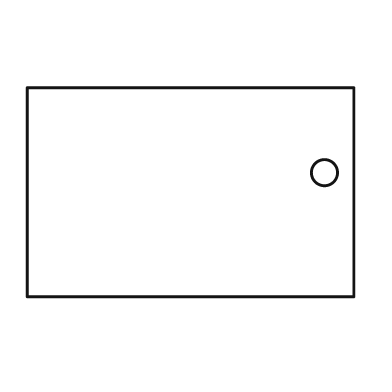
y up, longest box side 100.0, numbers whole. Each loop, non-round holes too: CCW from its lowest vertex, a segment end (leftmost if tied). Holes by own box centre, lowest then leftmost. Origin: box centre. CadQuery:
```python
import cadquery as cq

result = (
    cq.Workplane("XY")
    .moveTo(-50.0, -32.0)
    .lineTo(50.0, -32.0)
    .lineTo(50.0, 32.0)
    .lineTo(-50.0, 32.0)
    .close()
    .moveTo(41.0, 6.0)
    .circle(4.0)
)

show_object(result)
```